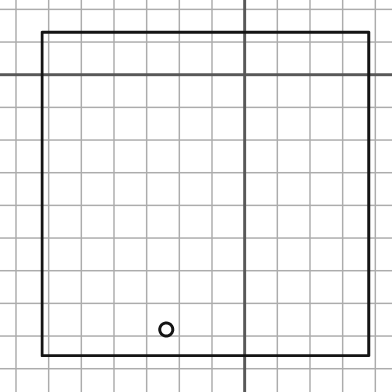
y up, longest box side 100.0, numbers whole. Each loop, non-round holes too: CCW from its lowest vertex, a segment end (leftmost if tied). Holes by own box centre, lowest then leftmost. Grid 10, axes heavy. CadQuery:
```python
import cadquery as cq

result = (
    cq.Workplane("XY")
    .moveTo(-62.0, -86.0)
    .lineTo(38.0, -86.0)
    .lineTo(38.0, 13.0)
    .lineTo(-62.0, 13.0)
    .close()
    .moveTo(-24.0, -78.0)
    .circle(2.0)
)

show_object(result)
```